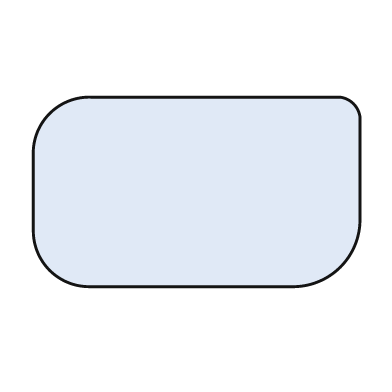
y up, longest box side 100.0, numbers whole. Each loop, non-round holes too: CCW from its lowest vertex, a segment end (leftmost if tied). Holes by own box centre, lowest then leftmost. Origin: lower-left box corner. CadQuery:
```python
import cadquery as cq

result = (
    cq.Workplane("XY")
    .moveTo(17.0, 0.0)
    .lineTo(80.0, 0.0)
    .threePointArc((94.0, 6.0), (100.0, 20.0))
    .lineTo(100.0, 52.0)
    .threePointArc((98.0, 56.0), (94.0, 58.0))
    .lineTo(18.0, 58.0)
    .threePointArc((5.0, 53.0), (0.0, 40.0))
    .lineTo(0.0, 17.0)
    .threePointArc((5.0, 5.0), (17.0, 0.0))
    .close()
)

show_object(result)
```